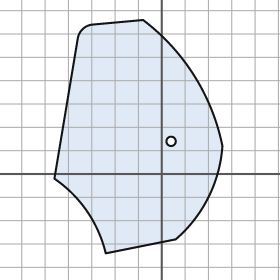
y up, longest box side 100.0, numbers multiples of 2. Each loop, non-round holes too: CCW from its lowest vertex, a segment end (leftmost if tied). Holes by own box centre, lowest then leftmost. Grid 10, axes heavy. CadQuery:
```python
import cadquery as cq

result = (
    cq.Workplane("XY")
    .moveTo(-24.0, -34.0)
    .lineTo(6.0, -28.0)
    .threePointArc((20.0, -10.0), (26.0, 12.0))
    .threePointArc((14.0, 42.0), (-8.0, 66.0))
    .lineTo(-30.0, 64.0)
    .threePointArc((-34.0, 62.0), (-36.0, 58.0))
    .lineTo(-46.0, -2.0)
    .threePointArc((-32.0, -16.0), (-24.0, -34.0))
    .close()
    .moveTo(4.0, 14.0)
    .circle(2.0)
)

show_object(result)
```